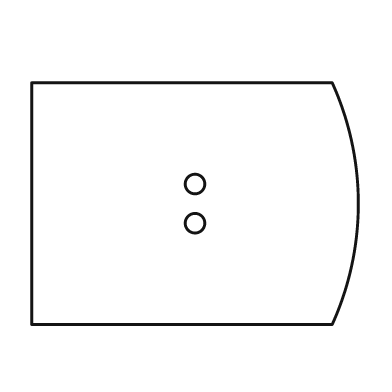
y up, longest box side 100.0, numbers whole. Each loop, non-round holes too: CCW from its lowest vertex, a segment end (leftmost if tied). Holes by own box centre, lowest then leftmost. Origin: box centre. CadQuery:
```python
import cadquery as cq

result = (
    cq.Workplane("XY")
    .moveTo(-50.0, -37.0)
    .lineTo(42.0, -37.0)
    .threePointArc((50.0, 0.0), (42.0, 37.0))
    .lineTo(-50.0, 37.0)
    .close()
    .moveTo(0.0, -6.0)
    .circle(3.0)
    .moveTo(0.0, 6.0)
    .circle(3.0)
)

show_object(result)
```